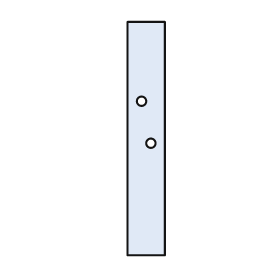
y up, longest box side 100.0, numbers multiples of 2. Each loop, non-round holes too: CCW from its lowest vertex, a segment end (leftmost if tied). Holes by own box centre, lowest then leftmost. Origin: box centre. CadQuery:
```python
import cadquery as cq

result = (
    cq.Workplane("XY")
    .moveTo(-8.0, -50.0)
    .lineTo(8.0, -50.0)
    .lineTo(8.0, 50.0)
    .lineTo(-8.0, 50.0)
    .close()
    .moveTo(2.0, -2.0)
    .circle(2.0)
    .moveTo(-2.0, 16.0)
    .circle(2.0)
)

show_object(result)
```